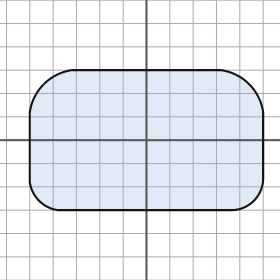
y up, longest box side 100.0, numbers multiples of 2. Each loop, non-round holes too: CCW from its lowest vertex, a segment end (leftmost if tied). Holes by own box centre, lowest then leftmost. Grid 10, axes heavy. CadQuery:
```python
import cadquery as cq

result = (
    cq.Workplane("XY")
    .moveTo(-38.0, -30.0)
    .lineTo(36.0, -30.0)
    .threePointArc((46.0, -26.0), (50.0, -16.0))
    .lineTo(50.0, 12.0)
    .threePointArc((44.0, 24.0), (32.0, 30.0))
    .lineTo(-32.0, 30.0)
    .threePointArc((-44.0, 24.0), (-50.0, 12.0))
    .lineTo(-50.0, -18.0)
    .threePointArc((-46.0, -26.0), (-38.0, -30.0))
    .close()
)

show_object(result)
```